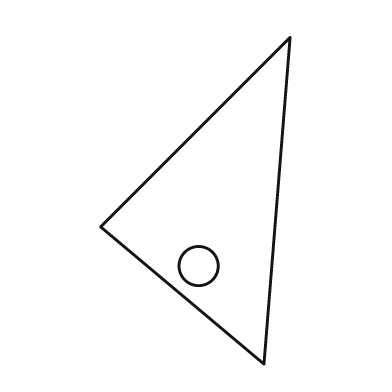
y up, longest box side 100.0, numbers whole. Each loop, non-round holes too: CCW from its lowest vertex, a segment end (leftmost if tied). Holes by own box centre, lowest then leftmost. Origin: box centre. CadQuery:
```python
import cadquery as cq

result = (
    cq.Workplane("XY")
    .moveTo(21.0, -50.0)
    .lineTo(29.0, 50.0)
    .lineTo(-29.0, -8.0)
    .close()
    .moveTo(1.0, -20.0)
    .circle(6.0)
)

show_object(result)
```